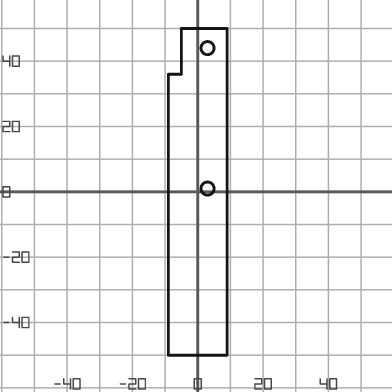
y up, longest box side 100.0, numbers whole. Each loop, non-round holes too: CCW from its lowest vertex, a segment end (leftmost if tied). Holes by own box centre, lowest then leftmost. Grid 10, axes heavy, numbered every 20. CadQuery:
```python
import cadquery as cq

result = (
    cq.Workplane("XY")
    .moveTo(-9.0, -50.0)
    .lineTo(9.0, -50.0)
    .lineTo(9.0, 50.0)
    .lineTo(-5.0, 50.0)
    .lineTo(-5.0, 36.0)
    .lineTo(-9.0, 36.0)
    .close()
    .moveTo(3.0, 1.0)
    .circle(2.0)
    .moveTo(3.0, 44.0)
    .circle(2.0)
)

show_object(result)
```